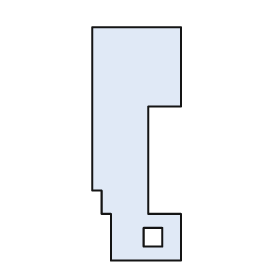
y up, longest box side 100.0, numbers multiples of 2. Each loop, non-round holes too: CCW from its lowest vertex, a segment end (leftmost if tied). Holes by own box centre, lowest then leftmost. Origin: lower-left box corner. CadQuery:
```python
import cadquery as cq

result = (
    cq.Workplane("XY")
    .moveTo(8.0, 0.0)
    .lineTo(38.0, 0.0)
    .lineTo(38.0, 20.0)
    .lineTo(24.0, 20.0)
    .lineTo(24.0, 66.0)
    .lineTo(38.0, 66.0)
    .lineTo(38.0, 100.0)
    .lineTo(0.0, 100.0)
    .lineTo(0.0, 30.0)
    .lineTo(4.0, 30.0)
    .lineTo(4.0, 20.0)
    .lineTo(8.0, 20.0)
    .close()
    .moveTo(22.0, 6.0)
    .lineTo(30.0, 6.0)
    .lineTo(30.0, 14.0)
    .lineTo(22.0, 14.0)
    .close()
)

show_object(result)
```